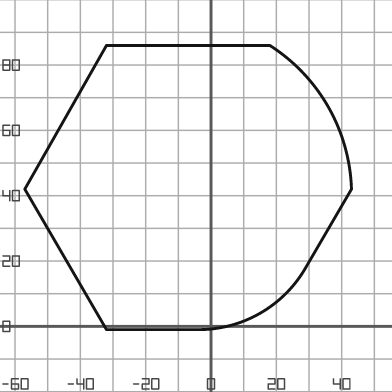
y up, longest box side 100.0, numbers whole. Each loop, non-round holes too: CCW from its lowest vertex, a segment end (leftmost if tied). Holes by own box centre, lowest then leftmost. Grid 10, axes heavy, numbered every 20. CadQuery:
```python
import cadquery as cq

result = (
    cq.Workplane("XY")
    .moveTo(-32.0, -1.0)
    .lineTo(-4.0, -1.0)
    .threePointArc((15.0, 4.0), (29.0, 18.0))
    .lineTo(43.0, 42.0)
    .threePointArc((36.0, 67.0), (18.0, 86.0))
    .lineTo(-32.0, 86.0)
    .lineTo(-57.0, 42.0)
    .close()
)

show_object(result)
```